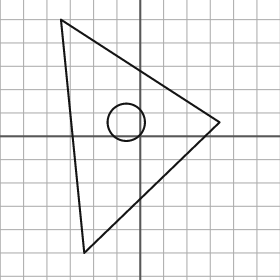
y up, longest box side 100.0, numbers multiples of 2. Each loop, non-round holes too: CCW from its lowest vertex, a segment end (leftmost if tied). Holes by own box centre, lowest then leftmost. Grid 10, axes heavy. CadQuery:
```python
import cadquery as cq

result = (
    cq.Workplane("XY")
    .moveTo(-24.0, -50.0)
    .lineTo(34.0, 6.0)
    .lineTo(-34.0, 50.0)
    .close()
    .moveTo(-6.0, 6.0)
    .circle(8.0)
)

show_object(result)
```